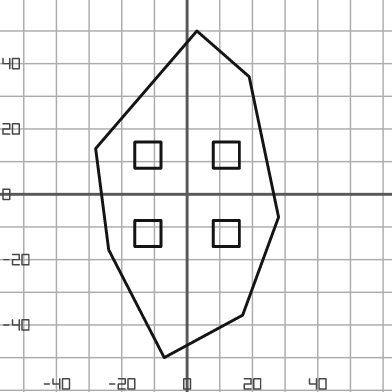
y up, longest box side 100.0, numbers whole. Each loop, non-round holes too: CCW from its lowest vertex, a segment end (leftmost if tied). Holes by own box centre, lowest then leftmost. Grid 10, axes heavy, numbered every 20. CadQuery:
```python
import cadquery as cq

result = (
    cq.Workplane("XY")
    .moveTo(-7.0, -50.0)
    .lineTo(17.0, -37.0)
    .lineTo(28.0, -7.0)
    .lineTo(19.0, 36.0)
    .lineTo(3.0, 50.0)
    .lineTo(-28.0, 14.0)
    .lineTo(-24.0, -17.0)
    .close()
    .moveTo(-16.0, -16.0)
    .lineTo(-8.0, -16.0)
    .lineTo(-8.0, -8.0)
    .lineTo(-16.0, -8.0)
    .close()
    .moveTo(8.0, -16.0)
    .lineTo(16.0, -16.0)
    .lineTo(16.0, -8.0)
    .lineTo(8.0, -8.0)
    .close()
    .moveTo(-16.0, 8.0)
    .lineTo(-8.0, 8.0)
    .lineTo(-8.0, 16.0)
    .lineTo(-16.0, 16.0)
    .close()
    .moveTo(8.0, 8.0)
    .lineTo(16.0, 8.0)
    .lineTo(16.0, 16.0)
    .lineTo(8.0, 16.0)
    .close()
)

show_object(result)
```